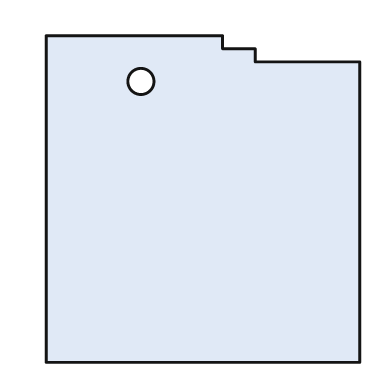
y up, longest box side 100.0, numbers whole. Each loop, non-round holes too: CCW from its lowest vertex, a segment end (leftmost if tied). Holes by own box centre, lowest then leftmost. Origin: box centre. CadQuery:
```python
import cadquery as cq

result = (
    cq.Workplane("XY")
    .moveTo(-48.0, -50.0)
    .lineTo(48.0, -50.0)
    .lineTo(48.0, 42.0)
    .lineTo(16.0, 42.0)
    .lineTo(16.0, 46.0)
    .lineTo(6.0, 46.0)
    .lineTo(6.0, 50.0)
    .lineTo(-48.0, 50.0)
    .close()
    .moveTo(-19.0, 36.0)
    .circle(4.0)
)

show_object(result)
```